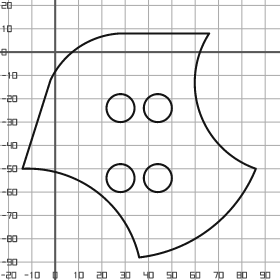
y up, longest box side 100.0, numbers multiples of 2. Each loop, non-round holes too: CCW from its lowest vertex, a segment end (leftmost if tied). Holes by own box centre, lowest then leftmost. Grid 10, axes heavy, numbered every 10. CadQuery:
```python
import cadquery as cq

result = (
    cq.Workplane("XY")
    .moveTo(36.0, -88.0)
    .threePointArc((66.0, -76.0), (86.0, -50.0))
    .threePointArc((62.0, -26.0), (66.0, 8.0))
    .lineTo(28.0, 8.0)
    .threePointArc((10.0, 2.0), (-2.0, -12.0))
    .lineTo(-14.0, -50.0)
    .threePointArc((18.0, -60.0), (36.0, -88.0))
    .close()
    .moveTo(28.0, -54.0)
    .circle(6.0)
    .moveTo(44.0, -54.0)
    .circle(6.0)
    .moveTo(28.0, -24.0)
    .circle(6.0)
    .moveTo(44.0, -24.0)
    .circle(6.0)
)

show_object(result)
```